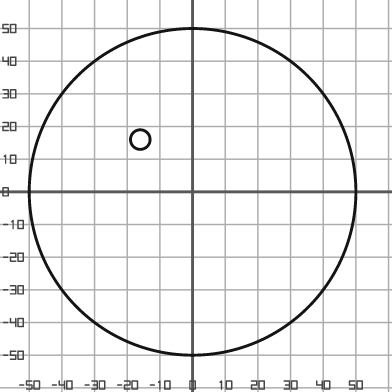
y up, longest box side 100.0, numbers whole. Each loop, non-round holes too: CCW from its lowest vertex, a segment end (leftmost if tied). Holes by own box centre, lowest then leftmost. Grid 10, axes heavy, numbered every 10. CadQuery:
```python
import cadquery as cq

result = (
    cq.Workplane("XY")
    .moveTo(0.0, 0.0)
    .circle(50.0)
    .moveTo(-16.0, 16.0)
    .circle(3.0)
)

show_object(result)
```